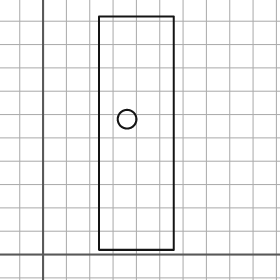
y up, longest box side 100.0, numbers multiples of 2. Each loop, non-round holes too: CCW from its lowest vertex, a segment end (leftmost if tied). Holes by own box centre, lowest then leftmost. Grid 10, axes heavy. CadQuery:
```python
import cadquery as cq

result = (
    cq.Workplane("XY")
    .moveTo(24.0, 2.0)
    .lineTo(56.0, 2.0)
    .lineTo(56.0, 102.0)
    .lineTo(24.0, 102.0)
    .close()
    .moveTo(36.0, 58.0)
    .circle(4.0)
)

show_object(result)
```